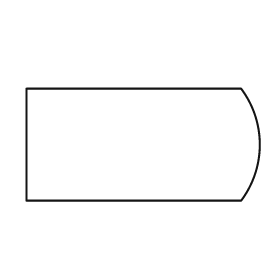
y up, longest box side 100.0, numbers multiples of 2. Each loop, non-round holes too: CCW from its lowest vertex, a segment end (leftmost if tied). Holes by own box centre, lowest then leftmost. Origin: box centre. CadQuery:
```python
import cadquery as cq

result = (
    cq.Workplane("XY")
    .moveTo(-50.0, -24.0)
    .lineTo(42.0, -24.0)
    .threePointArc((50.0, 0.0), (42.0, 24.0))
    .lineTo(-50.0, 24.0)
    .close()
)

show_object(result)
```